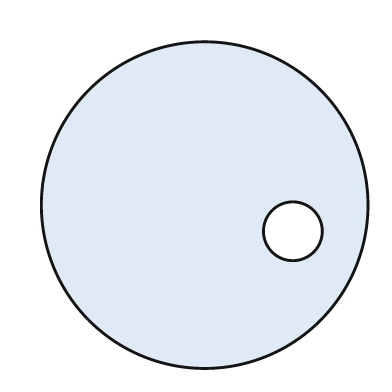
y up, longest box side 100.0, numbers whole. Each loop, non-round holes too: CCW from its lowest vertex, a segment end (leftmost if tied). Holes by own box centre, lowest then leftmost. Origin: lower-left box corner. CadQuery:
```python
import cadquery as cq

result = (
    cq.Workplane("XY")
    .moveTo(50.0, 50.0)
    .circle(50.0)
    .moveTo(77.0, 42.0)
    .circle(9.0)
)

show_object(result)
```